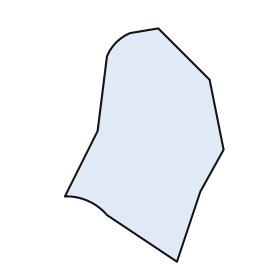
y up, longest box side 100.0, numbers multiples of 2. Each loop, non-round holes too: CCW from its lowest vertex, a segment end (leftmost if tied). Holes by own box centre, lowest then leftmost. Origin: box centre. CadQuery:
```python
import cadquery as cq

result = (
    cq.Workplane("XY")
    .moveTo(14.0, -50.0)
    .lineTo(24.0, -20.0)
    .lineTo(34.0, -2.0)
    .lineTo(28.0, 28.0)
    .lineTo(6.0, 50.0)
    .lineTo(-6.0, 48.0)
    .threePointArc((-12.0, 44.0), (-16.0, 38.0))
    .lineTo(-20.0, 6.0)
    .lineTo(-34.0, -22.0)
    .threePointArc((-24.0, -24.0), (-16.0, -30.0))
    .close()
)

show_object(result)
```